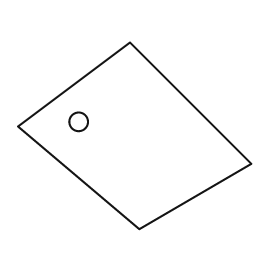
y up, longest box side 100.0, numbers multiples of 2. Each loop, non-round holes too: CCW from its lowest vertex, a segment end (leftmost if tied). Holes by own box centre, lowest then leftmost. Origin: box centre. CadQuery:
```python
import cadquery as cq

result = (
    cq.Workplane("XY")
    .moveTo(2.0, -40.0)
    .lineTo(50.0, -12.0)
    .lineTo(-2.0, 40.0)
    .lineTo(-50.0, 4.0)
    .close()
    .moveTo(-24.0, 6.0)
    .circle(4.0)
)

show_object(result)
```